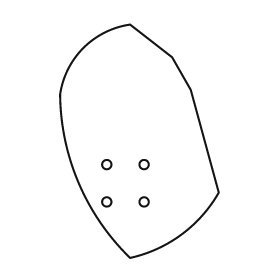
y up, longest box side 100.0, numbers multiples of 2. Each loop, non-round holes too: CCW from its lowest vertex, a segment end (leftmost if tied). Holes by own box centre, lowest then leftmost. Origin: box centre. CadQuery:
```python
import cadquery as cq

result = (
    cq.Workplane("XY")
    .moveTo(-4.0, -50.0)
    .threePointArc((18.0, -40.0), (34.0, -22.0))
    .lineTo(22.0, 22.0)
    .lineTo(14.0, 36.0)
    .lineTo(-4.0, 50.0)
    .threePointArc((-24.0, 40.0), (-34.0, 20.0))
    .threePointArc((-26.0, -18.0), (-4.0, -50.0))
    .close()
    .moveTo(-14.0, -26.0)
    .circle(2.0)
    .moveTo(2.0, -26.0)
    .circle(2.0)
    .moveTo(-14.0, -10.0)
    .circle(2.0)
    .moveTo(2.0, -10.0)
    .circle(2.0)
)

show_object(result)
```